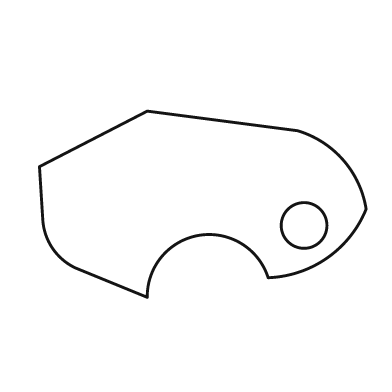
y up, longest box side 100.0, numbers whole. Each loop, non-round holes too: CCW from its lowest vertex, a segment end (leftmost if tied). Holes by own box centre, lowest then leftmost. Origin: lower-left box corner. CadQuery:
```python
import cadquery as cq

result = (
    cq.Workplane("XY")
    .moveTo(33.0, 0.0)
    .threePointArc((49.0, 19.0), (70.0, 6.0))
    .threePointArc((88.0, 12.0), (100.0, 27.0))
    .threePointArc((93.0, 42.0), (79.0, 51.0))
    .lineTo(33.0, 57.0)
    .lineTo(0.0, 40.0)
    .lineTo(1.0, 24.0)
    .threePointArc((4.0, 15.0), (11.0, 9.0))
    .close()
    .moveTo(81.0, 22.0)
    .circle(7.0)
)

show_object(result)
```